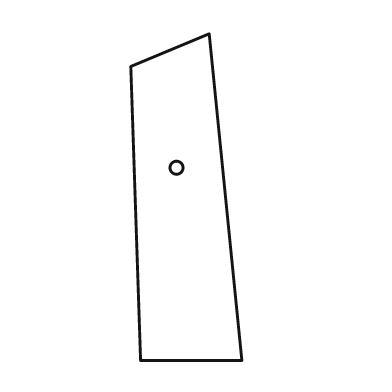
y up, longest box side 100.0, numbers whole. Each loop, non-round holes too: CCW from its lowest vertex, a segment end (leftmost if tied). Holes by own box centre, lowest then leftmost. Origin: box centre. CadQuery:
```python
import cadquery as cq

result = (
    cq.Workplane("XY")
    .moveTo(-14.0, -50.0)
    .lineTo(17.0, -50.0)
    .lineTo(7.0, 50.0)
    .lineTo(-17.0, 40.0)
    .close()
    .moveTo(-3.0, 9.0)
    .circle(2.0)
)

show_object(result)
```